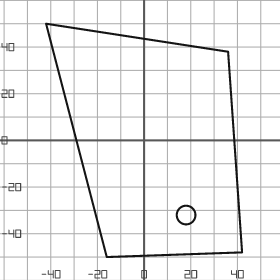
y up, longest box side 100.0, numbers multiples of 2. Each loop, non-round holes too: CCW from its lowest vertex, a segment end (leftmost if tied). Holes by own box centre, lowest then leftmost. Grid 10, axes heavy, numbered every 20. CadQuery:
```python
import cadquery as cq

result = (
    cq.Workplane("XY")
    .moveTo(-16.0, -50.0)
    .lineTo(42.0, -48.0)
    .lineTo(36.0, 38.0)
    .lineTo(-42.0, 50.0)
    .close()
    .moveTo(18.0, -32.0)
    .circle(4.0)
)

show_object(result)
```